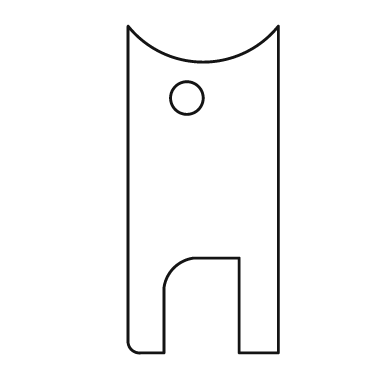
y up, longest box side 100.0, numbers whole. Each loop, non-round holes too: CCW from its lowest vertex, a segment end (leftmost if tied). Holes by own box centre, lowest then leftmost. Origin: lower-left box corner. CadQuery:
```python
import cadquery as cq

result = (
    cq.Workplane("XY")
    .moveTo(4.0, 0.0)
    .lineTo(11.0, 0.0)
    .lineTo(11.0, 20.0)
    .threePointArc((14.0, 26.0), (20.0, 29.0))
    .lineTo(34.0, 29.0)
    .lineTo(34.0, 0.0)
    .lineTo(46.0, 0.0)
    .lineTo(46.0, 100.0)
    .threePointArc((23.0, 89.0), (0.0, 100.0))
    .lineTo(0.0, 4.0)
    .threePointArc((1.0, 1.0), (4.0, 0.0))
    .close()
    .moveTo(18.0, 78.0)
    .circle(5.0)
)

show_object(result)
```